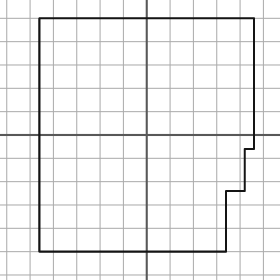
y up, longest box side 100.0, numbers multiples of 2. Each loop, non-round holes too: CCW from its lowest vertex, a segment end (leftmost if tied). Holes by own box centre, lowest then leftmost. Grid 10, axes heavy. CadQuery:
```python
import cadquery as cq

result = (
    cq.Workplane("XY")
    .moveTo(-46.0, -50.0)
    .lineTo(34.0, -50.0)
    .lineTo(34.0, -24.0)
    .lineTo(42.0, -24.0)
    .lineTo(42.0, -6.0)
    .lineTo(46.0, -6.0)
    .lineTo(46.0, 50.0)
    .lineTo(-46.0, 50.0)
    .close()
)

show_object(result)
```